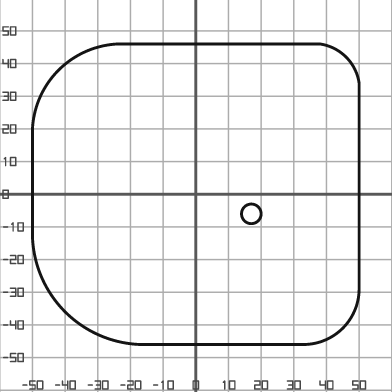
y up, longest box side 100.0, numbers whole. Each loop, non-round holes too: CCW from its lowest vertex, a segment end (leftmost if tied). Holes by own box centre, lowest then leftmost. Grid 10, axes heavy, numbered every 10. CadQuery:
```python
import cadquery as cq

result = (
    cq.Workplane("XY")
    .moveTo(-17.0, -46.0)
    .lineTo(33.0, -46.0)
    .threePointArc((45.0, -41.0), (50.0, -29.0))
    .lineTo(50.0, 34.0)
    .threePointArc((46.0, 42.0), (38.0, 46.0))
    .lineTo(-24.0, 46.0)
    .threePointArc((-42.0, 38.0), (-50.0, 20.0))
    .lineTo(-50.0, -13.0)
    .threePointArc((-40.0, -36.0), (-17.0, -46.0))
    .close()
    .moveTo(17.0, -6.0)
    .circle(3.0)
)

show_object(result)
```